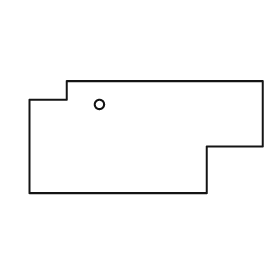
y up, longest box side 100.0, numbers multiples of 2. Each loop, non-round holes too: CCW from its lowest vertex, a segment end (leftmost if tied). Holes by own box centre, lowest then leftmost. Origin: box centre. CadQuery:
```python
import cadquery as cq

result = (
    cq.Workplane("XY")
    .moveTo(-50.0, -24.0)
    .lineTo(26.0, -24.0)
    .lineTo(26.0, -4.0)
    .lineTo(50.0, -4.0)
    .lineTo(50.0, 24.0)
    .lineTo(-34.0, 24.0)
    .lineTo(-34.0, 16.0)
    .lineTo(-50.0, 16.0)
    .close()
    .moveTo(-20.0, 14.0)
    .circle(2.0)
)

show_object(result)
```